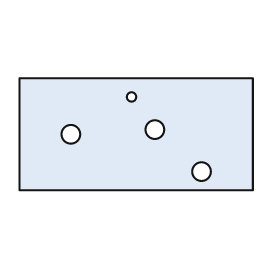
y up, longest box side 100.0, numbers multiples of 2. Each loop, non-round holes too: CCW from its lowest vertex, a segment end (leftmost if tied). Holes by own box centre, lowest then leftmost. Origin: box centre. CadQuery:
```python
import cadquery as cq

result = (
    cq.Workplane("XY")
    .moveTo(-50.0, -24.0)
    .lineTo(50.0, -24.0)
    .lineTo(50.0, 24.0)
    .lineTo(-50.0, 24.0)
    .close()
    .moveTo(28.0, -16.0)
    .circle(4.0)
    .moveTo(-28.0, 0.0)
    .circle(4.0)
    .moveTo(8.0, 2.0)
    .circle(4.0)
    .moveTo(-2.0, 16.0)
    .circle(2.0)
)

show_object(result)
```